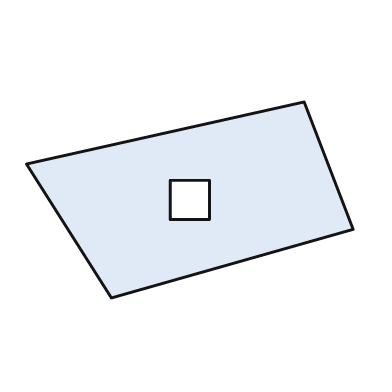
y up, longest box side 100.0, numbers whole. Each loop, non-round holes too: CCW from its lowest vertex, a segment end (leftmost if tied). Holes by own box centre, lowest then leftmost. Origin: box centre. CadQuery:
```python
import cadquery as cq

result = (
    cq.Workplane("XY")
    .moveTo(-24.0, -30.0)
    .lineTo(50.0, -9.0)
    .lineTo(35.0, 30.0)
    .lineTo(-50.0, 11.0)
    .close()
    .moveTo(-6.0, -6.0)
    .lineTo(6.0, -6.0)
    .lineTo(6.0, 6.0)
    .lineTo(-6.0, 6.0)
    .close()
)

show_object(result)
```